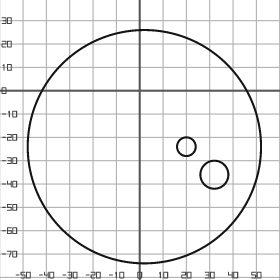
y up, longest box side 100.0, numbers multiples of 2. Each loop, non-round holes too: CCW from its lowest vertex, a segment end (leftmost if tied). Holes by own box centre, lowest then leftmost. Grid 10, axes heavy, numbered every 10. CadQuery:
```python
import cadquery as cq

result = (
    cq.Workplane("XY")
    .moveTo(2.0, -24.0)
    .circle(50.0)
    .moveTo(32.0, -36.0)
    .circle(6.0)
    .moveTo(20.0, -24.0)
    .circle(4.0)
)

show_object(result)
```